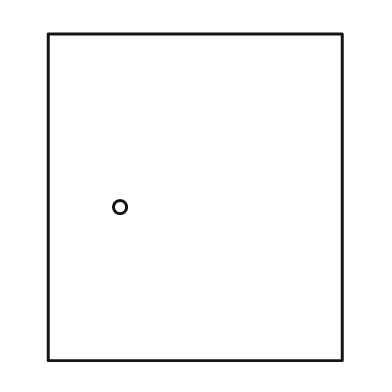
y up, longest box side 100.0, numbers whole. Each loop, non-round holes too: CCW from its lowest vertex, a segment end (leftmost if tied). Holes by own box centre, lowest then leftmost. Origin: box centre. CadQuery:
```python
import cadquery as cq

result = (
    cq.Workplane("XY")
    .moveTo(-45.0, -50.0)
    .lineTo(45.0, -50.0)
    .lineTo(45.0, 50.0)
    .lineTo(-45.0, 50.0)
    .close()
    .moveTo(-23.0, -3.0)
    .circle(2.0)
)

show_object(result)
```